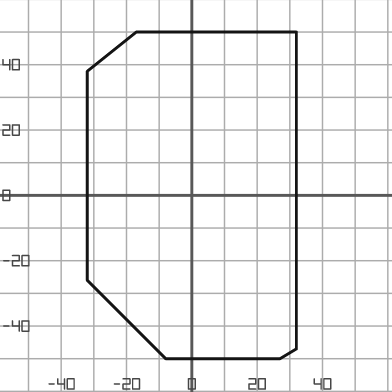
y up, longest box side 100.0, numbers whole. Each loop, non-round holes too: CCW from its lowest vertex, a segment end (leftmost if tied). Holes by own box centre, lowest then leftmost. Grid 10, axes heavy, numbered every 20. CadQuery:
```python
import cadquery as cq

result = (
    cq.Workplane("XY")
    .moveTo(-8.0, -50.0)
    .lineTo(27.0, -50.0)
    .lineTo(32.0, -47.0)
    .lineTo(32.0, 50.0)
    .lineTo(-17.0, 50.0)
    .lineTo(-32.0, 38.0)
    .lineTo(-32.0, -26.0)
    .close()
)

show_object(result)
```